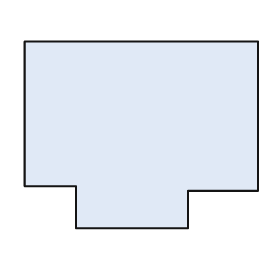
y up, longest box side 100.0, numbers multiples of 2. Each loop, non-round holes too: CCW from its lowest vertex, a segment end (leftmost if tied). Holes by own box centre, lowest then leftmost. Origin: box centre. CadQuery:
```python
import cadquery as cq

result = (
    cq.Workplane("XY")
    .moveTo(-28.0, -40.0)
    .lineTo(20.0, -40.0)
    .lineTo(20.0, -24.0)
    .lineTo(50.0, -24.0)
    .lineTo(50.0, 40.0)
    .lineTo(-50.0, 40.0)
    .lineTo(-50.0, -22.0)
    .lineTo(-28.0, -22.0)
    .close()
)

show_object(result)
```